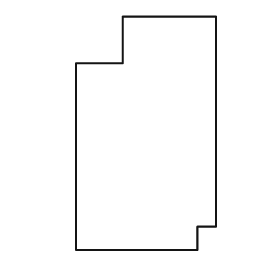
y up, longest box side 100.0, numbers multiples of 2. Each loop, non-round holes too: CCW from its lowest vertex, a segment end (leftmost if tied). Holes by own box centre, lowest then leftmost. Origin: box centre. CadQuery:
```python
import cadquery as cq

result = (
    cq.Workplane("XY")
    .moveTo(-30.0, -50.0)
    .lineTo(22.0, -50.0)
    .lineTo(22.0, -40.0)
    .lineTo(30.0, -40.0)
    .lineTo(30.0, 50.0)
    .lineTo(-10.0, 50.0)
    .lineTo(-10.0, 30.0)
    .lineTo(-30.0, 30.0)
    .close()
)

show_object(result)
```